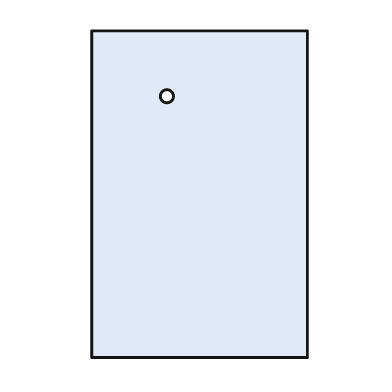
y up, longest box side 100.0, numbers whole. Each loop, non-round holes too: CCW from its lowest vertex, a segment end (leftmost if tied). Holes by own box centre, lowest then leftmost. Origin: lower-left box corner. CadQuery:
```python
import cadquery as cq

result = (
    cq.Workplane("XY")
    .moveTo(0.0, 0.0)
    .lineTo(66.0, 0.0)
    .lineTo(66.0, 100.0)
    .lineTo(0.0, 100.0)
    .close()
    .moveTo(23.0, 80.0)
    .circle(2.0)
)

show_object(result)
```